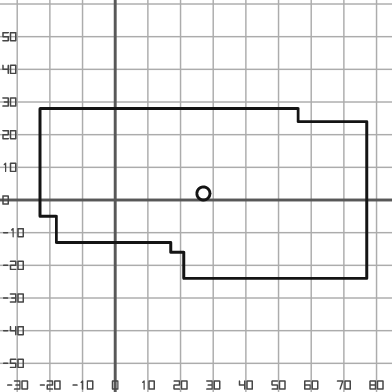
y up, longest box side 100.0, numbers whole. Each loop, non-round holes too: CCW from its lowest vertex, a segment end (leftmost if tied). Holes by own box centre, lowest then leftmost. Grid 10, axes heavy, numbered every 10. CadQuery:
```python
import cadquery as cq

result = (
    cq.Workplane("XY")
    .moveTo(21.0, -24.0)
    .lineTo(77.0, -24.0)
    .lineTo(77.0, 24.0)
    .lineTo(56.0, 24.0)
    .lineTo(56.0, 28.0)
    .lineTo(-23.0, 28.0)
    .lineTo(-23.0, -5.0)
    .lineTo(-18.0, -5.0)
    .lineTo(-18.0, -13.0)
    .lineTo(17.0, -13.0)
    .lineTo(17.0, -16.0)
    .lineTo(21.0, -16.0)
    .close()
    .moveTo(27.0, 2.0)
    .circle(2.0)
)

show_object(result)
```